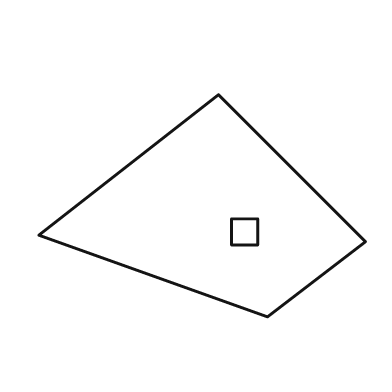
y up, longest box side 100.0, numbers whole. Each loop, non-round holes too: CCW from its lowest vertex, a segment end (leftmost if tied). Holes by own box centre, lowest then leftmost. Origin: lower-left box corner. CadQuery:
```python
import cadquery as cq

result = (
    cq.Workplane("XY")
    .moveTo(70.0, 0.0)
    .lineTo(100.0, 23.0)
    .lineTo(55.0, 68.0)
    .lineTo(0.0, 25.0)
    .close()
    .moveTo(59.0, 22.0)
    .lineTo(67.0, 22.0)
    .lineTo(67.0, 30.0)
    .lineTo(59.0, 30.0)
    .close()
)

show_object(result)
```